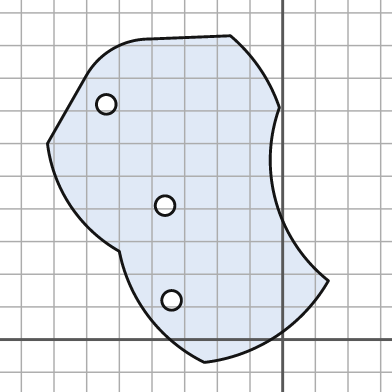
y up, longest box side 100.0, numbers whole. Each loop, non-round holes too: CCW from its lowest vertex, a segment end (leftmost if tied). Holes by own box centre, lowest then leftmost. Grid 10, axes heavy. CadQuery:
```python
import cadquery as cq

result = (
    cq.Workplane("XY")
    .moveTo(-24.0, -7.0)
    .threePointArc((-2.0, 1.0), (14.0, 18.0))
    .threePointArc((-2.0, 42.0), (-1.0, 71.0))
    .threePointArc((-7.0, 83.0), (-16.0, 93.0))
    .lineTo(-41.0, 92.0)
    .threePointArc((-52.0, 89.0), (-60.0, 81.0))
    .lineTo(-72.0, 60.0)
    .threePointArc((-65.0, 41.0), (-50.0, 27.0))
    .threePointArc((-41.0, 7.0), (-24.0, -7.0))
    .close()
    .moveTo(-34.0, 12.0)
    .circle(3.0)
    .moveTo(-36.0, 41.0)
    .circle(3.0)
    .moveTo(-54.0, 72.0)
    .circle(3.0)
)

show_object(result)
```